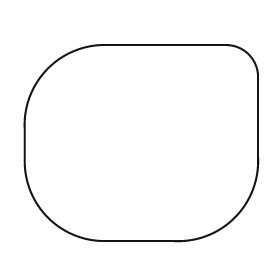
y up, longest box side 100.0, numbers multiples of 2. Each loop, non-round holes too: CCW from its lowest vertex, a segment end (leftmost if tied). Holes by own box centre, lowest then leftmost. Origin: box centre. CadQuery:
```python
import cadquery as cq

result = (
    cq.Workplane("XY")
    .moveTo(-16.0, -42.0)
    .lineTo(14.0, -42.0)
    .threePointArc((40.0, -32.0), (50.0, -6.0))
    .lineTo(50.0, 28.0)
    .threePointArc((46.0, 38.0), (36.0, 42.0))
    .lineTo(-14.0, 42.0)
    .threePointArc((-40.0, 32.0), (-50.0, 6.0))
    .lineTo(-50.0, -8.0)
    .threePointArc((-40.0, -32.0), (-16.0, -42.0))
    .close()
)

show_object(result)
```